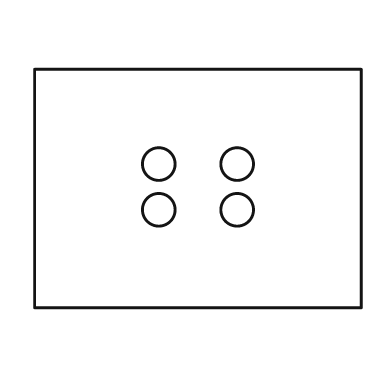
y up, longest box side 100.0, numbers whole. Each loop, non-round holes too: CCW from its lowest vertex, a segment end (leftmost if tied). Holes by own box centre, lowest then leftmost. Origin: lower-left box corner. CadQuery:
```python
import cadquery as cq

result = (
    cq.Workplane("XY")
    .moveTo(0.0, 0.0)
    .lineTo(100.0, 0.0)
    .lineTo(100.0, 73.0)
    .lineTo(0.0, 73.0)
    .close()
    .moveTo(38.0, 30.0)
    .circle(5.0)
    .moveTo(62.0, 30.0)
    .circle(5.0)
    .moveTo(38.0, 44.0)
    .circle(5.0)
    .moveTo(62.0, 44.0)
    .circle(5.0)
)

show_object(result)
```